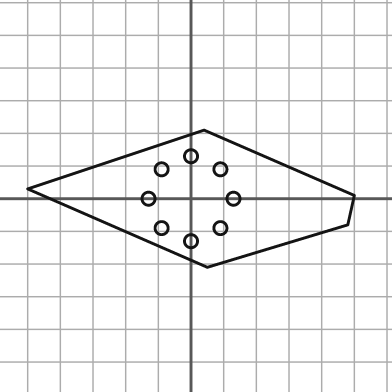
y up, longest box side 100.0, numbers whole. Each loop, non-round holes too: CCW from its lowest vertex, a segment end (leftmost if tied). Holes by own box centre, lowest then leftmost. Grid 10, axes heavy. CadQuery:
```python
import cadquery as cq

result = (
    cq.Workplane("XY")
    .moveTo(5.0, -21.0)
    .lineTo(48.0, -8.0)
    .lineTo(50.0, 1.0)
    .lineTo(4.0, 21.0)
    .lineTo(-50.0, 3.0)
    .close()
    .moveTo(0.0, -13.0)
    .circle(2.0)
    .moveTo(-9.0, -9.0)
    .circle(2.0)
    .moveTo(9.0, -9.0)
    .circle(2.0)
    .moveTo(-13.0, 0.0)
    .circle(2.0)
    .moveTo(13.0, 0.0)
    .circle(2.0)
    .moveTo(-9.0, 9.0)
    .circle(2.0)
    .moveTo(9.0, 9.0)
    .circle(2.0)
    .moveTo(0.0, 13.0)
    .circle(2.0)
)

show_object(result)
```